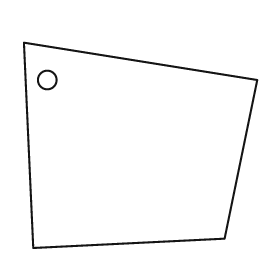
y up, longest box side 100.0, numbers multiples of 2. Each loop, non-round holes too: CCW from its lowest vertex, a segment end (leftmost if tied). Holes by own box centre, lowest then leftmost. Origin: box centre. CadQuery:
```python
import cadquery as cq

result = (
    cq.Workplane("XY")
    .moveTo(-46.0, -44.0)
    .lineTo(36.0, -40.0)
    .lineTo(50.0, 28.0)
    .lineTo(-50.0, 44.0)
    .close()
    .moveTo(-40.0, 28.0)
    .circle(4.0)
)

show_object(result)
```